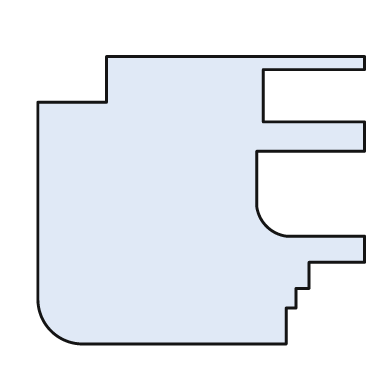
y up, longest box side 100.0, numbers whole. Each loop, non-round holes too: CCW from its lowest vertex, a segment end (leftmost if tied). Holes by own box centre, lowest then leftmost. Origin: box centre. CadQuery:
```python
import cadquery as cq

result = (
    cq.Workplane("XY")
    .moveTo(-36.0, -44.0)
    .lineTo(26.0, -44.0)
    .lineTo(26.0, -33.0)
    .lineTo(29.0, -33.0)
    .lineTo(29.0, -27.0)
    .lineTo(33.0, -27.0)
    .lineTo(33.0, -19.0)
    .lineTo(50.0, -19.0)
    .lineTo(50.0, -11.0)
    .lineTo(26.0, -11.0)
    .threePointArc((20.0, -8.0), (17.0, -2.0))
    .lineTo(17.0, 15.0)
    .lineTo(50.0, 15.0)
    .lineTo(50.0, 24.0)
    .lineTo(19.0, 24.0)
    .lineTo(19.0, 40.0)
    .lineTo(50.0, 40.0)
    .lineTo(50.0, 44.0)
    .lineTo(-29.0, 44.0)
    .lineTo(-29.0, 30.0)
    .lineTo(-50.0, 30.0)
    .lineTo(-50.0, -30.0)
    .threePointArc((-46.0, -40.0), (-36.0, -44.0))
    .close()
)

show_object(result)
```